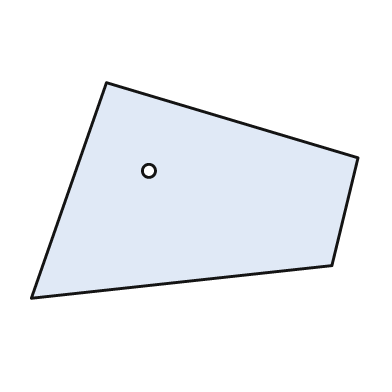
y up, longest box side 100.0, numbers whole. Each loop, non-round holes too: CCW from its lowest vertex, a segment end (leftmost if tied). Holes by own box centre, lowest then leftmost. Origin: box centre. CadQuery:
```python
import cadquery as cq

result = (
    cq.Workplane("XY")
    .moveTo(-50.0, -33.0)
    .lineTo(42.0, -23.0)
    .lineTo(50.0, 10.0)
    .lineTo(-27.0, 33.0)
    .close()
    .moveTo(-14.0, 6.0)
    .circle(2.0)
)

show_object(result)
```